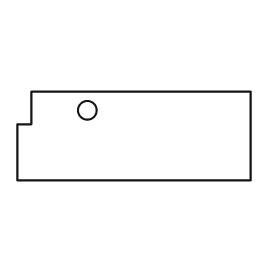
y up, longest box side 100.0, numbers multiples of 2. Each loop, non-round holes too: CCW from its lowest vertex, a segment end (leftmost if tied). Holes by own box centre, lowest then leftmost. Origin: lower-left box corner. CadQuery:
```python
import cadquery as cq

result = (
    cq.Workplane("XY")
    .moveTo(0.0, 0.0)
    .lineTo(100.0, 0.0)
    .lineTo(100.0, 38.0)
    .lineTo(6.0, 38.0)
    .lineTo(6.0, 24.0)
    .lineTo(0.0, 24.0)
    .close()
    .moveTo(30.0, 30.0)
    .circle(4.0)
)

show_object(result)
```